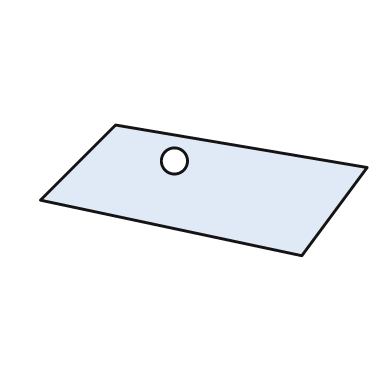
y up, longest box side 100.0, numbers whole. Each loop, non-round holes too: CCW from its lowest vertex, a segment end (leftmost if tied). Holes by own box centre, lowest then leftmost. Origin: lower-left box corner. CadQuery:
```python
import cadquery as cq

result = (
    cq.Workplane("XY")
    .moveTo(80.0, 0.0)
    .lineTo(100.0, 27.0)
    .lineTo(23.0, 40.0)
    .lineTo(0.0, 17.0)
    .close()
    .moveTo(41.0, 29.0)
    .circle(4.0)
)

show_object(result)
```